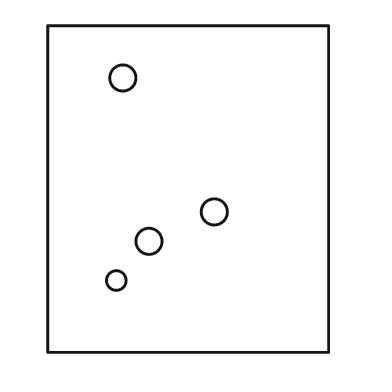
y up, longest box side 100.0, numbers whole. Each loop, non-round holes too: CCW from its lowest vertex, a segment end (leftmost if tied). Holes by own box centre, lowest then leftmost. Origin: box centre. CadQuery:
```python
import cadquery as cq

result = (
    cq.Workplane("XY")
    .moveTo(-43.0, -50.0)
    .lineTo(43.0, -50.0)
    .lineTo(43.0, 50.0)
    .lineTo(-43.0, 50.0)
    .close()
    .moveTo(-22.0, -28.0)
    .circle(3.0)
    .moveTo(-12.0, -16.0)
    .circle(4.0)
    .moveTo(8.0, -7.0)
    .circle(4.0)
    .moveTo(-20.0, 34.0)
    .circle(4.0)
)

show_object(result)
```